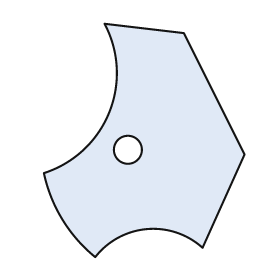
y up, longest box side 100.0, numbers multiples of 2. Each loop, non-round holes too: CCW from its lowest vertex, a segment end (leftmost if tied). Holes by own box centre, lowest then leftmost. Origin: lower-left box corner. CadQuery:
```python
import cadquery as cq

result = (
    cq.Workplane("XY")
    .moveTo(22.0, 0.0)
    .threePointArc((44.0, 12.0), (68.0, 4.0))
    .lineTo(86.0, 44.0)
    .lineTo(60.0, 96.0)
    .lineTo(26.0, 100.0)
    .threePointArc((28.0, 62.0), (0.0, 36.0))
    .threePointArc((8.0, 16.0), (22.0, 0.0))
    .close()
    .moveTo(36.0, 46.0)
    .circle(6.0)
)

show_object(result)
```